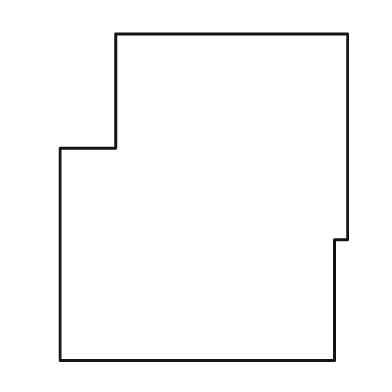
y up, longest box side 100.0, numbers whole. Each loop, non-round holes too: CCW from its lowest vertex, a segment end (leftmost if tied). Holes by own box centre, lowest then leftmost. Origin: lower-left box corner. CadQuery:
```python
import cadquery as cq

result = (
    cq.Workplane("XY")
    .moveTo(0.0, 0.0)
    .lineTo(84.0, 0.0)
    .lineTo(84.0, 37.0)
    .lineTo(88.0, 37.0)
    .lineTo(88.0, 100.0)
    .lineTo(17.0, 100.0)
    .lineTo(17.0, 65.0)
    .lineTo(0.0, 65.0)
    .close()
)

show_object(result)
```